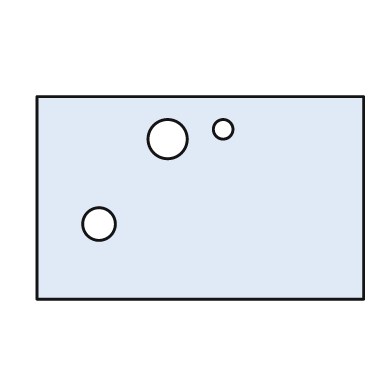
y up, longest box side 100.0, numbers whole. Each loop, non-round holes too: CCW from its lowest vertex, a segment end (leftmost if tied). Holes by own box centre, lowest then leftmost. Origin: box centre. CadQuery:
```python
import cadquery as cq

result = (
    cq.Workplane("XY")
    .moveTo(-50.0, -31.0)
    .lineTo(50.0, -31.0)
    .lineTo(50.0, 31.0)
    .lineTo(-50.0, 31.0)
    .close()
    .moveTo(-31.0, -8.0)
    .circle(5.0)
    .moveTo(-10.0, 18.0)
    .circle(6.0)
    .moveTo(7.0, 21.0)
    .circle(3.0)
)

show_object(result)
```